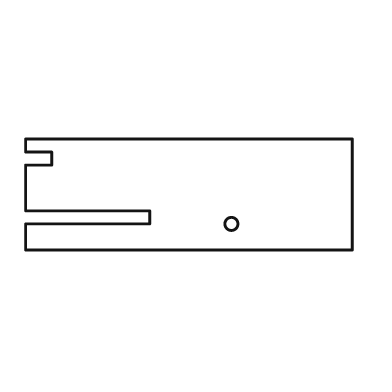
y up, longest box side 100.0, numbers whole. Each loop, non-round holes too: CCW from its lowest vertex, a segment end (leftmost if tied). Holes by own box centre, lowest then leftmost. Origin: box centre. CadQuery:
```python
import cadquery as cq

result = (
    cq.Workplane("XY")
    .moveTo(-50.0, -17.0)
    .lineTo(50.0, -17.0)
    .lineTo(50.0, 17.0)
    .lineTo(-50.0, 17.0)
    .lineTo(-50.0, 13.0)
    .lineTo(-42.0, 13.0)
    .lineTo(-42.0, 9.0)
    .lineTo(-50.0, 9.0)
    .lineTo(-50.0, -5.0)
    .lineTo(-12.0, -5.0)
    .lineTo(-12.0, -9.0)
    .lineTo(-50.0, -9.0)
    .close()
    .moveTo(13.0, -9.0)
    .circle(2.0)
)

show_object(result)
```